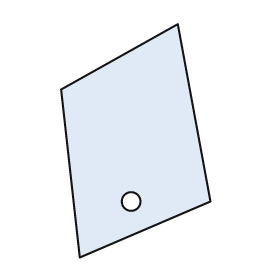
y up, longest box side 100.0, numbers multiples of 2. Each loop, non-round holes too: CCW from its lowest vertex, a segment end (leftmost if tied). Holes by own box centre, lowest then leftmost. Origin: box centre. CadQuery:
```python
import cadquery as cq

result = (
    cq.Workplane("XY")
    .moveTo(-24.0, -50.0)
    .lineTo(32.0, -26.0)
    .lineTo(18.0, 50.0)
    .lineTo(-32.0, 22.0)
    .close()
    .moveTo(-2.0, -26.0)
    .circle(4.0)
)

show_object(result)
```